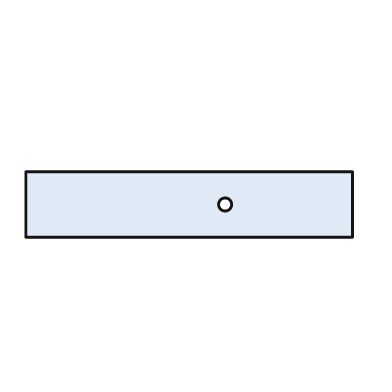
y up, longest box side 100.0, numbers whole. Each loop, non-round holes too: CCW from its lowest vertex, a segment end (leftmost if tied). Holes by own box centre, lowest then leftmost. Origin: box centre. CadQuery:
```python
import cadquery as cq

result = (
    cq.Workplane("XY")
    .moveTo(-50.0, -10.0)
    .lineTo(50.0, -10.0)
    .lineTo(50.0, 10.0)
    .lineTo(-50.0, 10.0)
    .close()
    .moveTo(11.0, 0.0)
    .circle(2.0)
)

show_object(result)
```